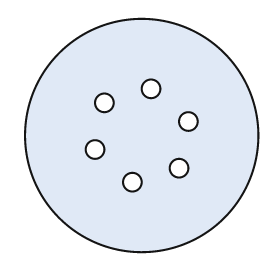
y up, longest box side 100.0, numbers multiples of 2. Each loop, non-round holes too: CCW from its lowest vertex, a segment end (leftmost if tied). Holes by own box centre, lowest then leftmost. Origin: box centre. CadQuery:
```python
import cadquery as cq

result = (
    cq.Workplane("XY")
    .moveTo(0.0, 0.0)
    .circle(50.0)
    .moveTo(-4.0, -20.0)
    .circle(4.0)
    .moveTo(16.0, -14.0)
    .circle(4.0)
    .moveTo(-20.0, -6.0)
    .circle(4.0)
    .moveTo(20.0, 6.0)
    .circle(4.0)
    .moveTo(-16.0, 14.0)
    .circle(4.0)
    .moveTo(4.0, 20.0)
    .circle(4.0)
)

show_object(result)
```